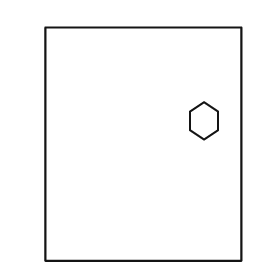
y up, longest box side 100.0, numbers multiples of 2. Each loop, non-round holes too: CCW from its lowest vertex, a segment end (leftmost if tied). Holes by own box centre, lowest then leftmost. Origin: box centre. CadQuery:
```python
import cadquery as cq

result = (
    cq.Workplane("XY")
    .moveTo(-42.0, -50.0)
    .lineTo(42.0, -50.0)
    .lineTo(42.0, 50.0)
    .lineTo(-42.0, 50.0)
    .close()
    .moveTo(26.0, 2.0)
    .lineTo(32.0, 6.0)
    .lineTo(32.0, 14.0)
    .lineTo(26.0, 18.0)
    .lineTo(20.0, 14.0)
    .lineTo(20.0, 6.0)
    .close()
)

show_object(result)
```